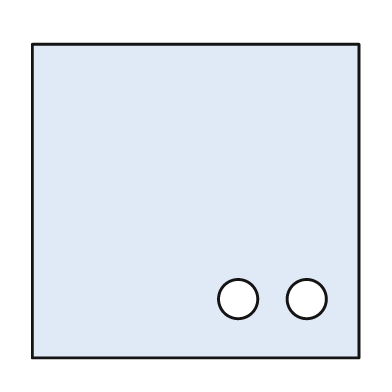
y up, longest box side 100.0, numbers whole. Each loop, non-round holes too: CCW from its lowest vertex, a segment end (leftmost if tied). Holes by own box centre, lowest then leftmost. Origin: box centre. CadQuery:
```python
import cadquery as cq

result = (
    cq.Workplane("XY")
    .moveTo(-50.0, -48.0)
    .lineTo(50.0, -48.0)
    .lineTo(50.0, 48.0)
    .lineTo(-50.0, 48.0)
    .close()
    .moveTo(13.0, -30.0)
    .circle(6.0)
    .moveTo(34.0, -30.0)
    .circle(6.0)
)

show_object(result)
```